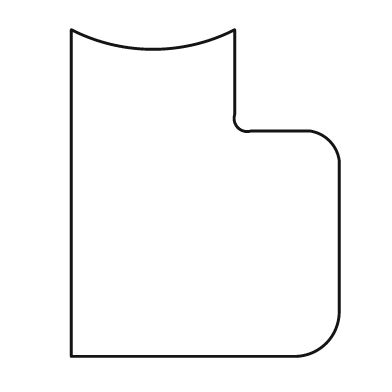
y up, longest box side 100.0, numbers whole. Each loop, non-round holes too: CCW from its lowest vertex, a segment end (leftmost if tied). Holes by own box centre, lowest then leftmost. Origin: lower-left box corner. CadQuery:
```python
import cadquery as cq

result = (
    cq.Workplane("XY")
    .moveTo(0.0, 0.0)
    .lineTo(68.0, 0.0)
    .threePointArc((78.0, 4.0), (82.0, 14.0))
    .lineTo(82.0, 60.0)
    .threePointArc((79.0, 66.0), (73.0, 69.0))
    .lineTo(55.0, 69.0)
    .threePointArc((51.0, 70.0), (50.0, 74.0))
    .lineTo(50.0, 100.0)
    .threePointArc((25.0, 94.0), (0.0, 100.0))
    .close()
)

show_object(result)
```